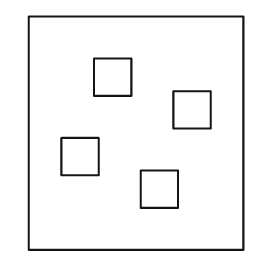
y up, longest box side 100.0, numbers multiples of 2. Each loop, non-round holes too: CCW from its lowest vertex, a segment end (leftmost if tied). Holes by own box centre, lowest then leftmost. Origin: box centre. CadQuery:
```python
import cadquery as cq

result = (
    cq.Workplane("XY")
    .moveTo(-46.0, -50.0)
    .lineTo(46.0, -50.0)
    .lineTo(46.0, 50.0)
    .lineTo(-46.0, 50.0)
    .close()
    .moveTo(2.0, -32.0)
    .lineTo(18.0, -32.0)
    .lineTo(18.0, -16.0)
    .lineTo(2.0, -16.0)
    .close()
    .moveTo(-32.0, -18.0)
    .lineTo(-16.0, -18.0)
    .lineTo(-16.0, -2.0)
    .lineTo(-32.0, -2.0)
    .close()
    .moveTo(16.0, 2.0)
    .lineTo(32.0, 2.0)
    .lineTo(32.0, 18.0)
    .lineTo(16.0, 18.0)
    .close()
    .moveTo(-18.0, 16.0)
    .lineTo(-2.0, 16.0)
    .lineTo(-2.0, 32.0)
    .lineTo(-18.0, 32.0)
    .close()
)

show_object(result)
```